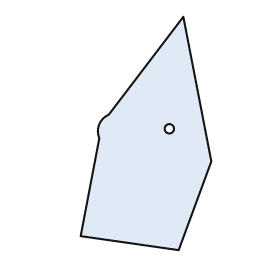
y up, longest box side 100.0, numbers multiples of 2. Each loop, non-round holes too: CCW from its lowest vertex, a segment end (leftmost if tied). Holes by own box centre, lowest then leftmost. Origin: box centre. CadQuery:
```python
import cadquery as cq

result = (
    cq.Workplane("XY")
    .moveTo(14.0, -50.0)
    .lineTo(28.0, -12.0)
    .lineTo(16.0, 50.0)
    .lineTo(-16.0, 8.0)
    .threePointArc((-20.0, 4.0), (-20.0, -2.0))
    .lineTo(-28.0, -44.0)
    .close()
    .moveTo(10.0, 2.0)
    .circle(2.0)
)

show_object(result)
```